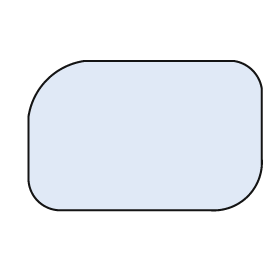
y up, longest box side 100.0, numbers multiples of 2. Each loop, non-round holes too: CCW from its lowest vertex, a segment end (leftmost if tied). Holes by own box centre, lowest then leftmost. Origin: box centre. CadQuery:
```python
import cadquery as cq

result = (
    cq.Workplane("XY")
    .moveTo(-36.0, -32.0)
    .lineTo(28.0, -32.0)
    .threePointArc((44.0, -26.0), (50.0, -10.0))
    .lineTo(50.0, 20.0)
    .threePointArc((46.0, 28.0), (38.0, 32.0))
    .lineTo(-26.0, 32.0)
    .threePointArc((-42.0, 24.0), (-50.0, 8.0))
    .lineTo(-50.0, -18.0)
    .threePointArc((-46.0, -28.0), (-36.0, -32.0))
    .close()
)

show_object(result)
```